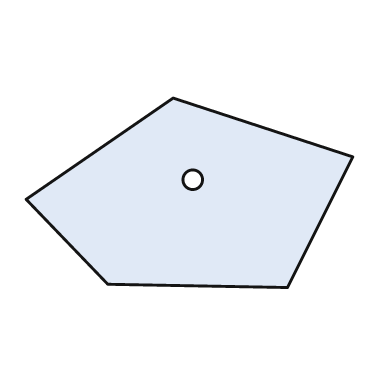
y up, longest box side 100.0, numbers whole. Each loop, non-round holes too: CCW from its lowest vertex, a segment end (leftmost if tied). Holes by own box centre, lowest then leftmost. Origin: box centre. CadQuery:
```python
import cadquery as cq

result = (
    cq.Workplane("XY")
    .moveTo(30.0, -29.0)
    .lineTo(50.0, 11.0)
    .lineTo(-5.0, 29.0)
    .lineTo(-50.0, -2.0)
    .lineTo(-25.0, -28.0)
    .close()
    .moveTo(1.0, 4.0)
    .circle(3.0)
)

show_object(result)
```